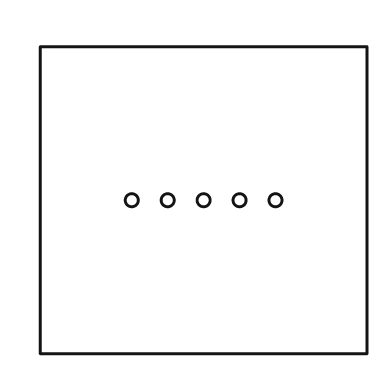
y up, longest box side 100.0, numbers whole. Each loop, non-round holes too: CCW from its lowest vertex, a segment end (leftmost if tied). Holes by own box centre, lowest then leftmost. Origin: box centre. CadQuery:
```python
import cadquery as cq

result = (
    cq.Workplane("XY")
    .moveTo(-50.0, -47.0)
    .lineTo(50.0, -47.0)
    .lineTo(50.0, 47.0)
    .lineTo(-50.0, 47.0)
    .close()
    .moveTo(-22.0, 0.0)
    .circle(2.0)
    .moveTo(-11.0, 0.0)
    .circle(2.0)
    .moveTo(0.0, 0.0)
    .circle(2.0)
    .moveTo(11.0, 0.0)
    .circle(2.0)
    .moveTo(22.0, 0.0)
    .circle(2.0)
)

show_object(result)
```